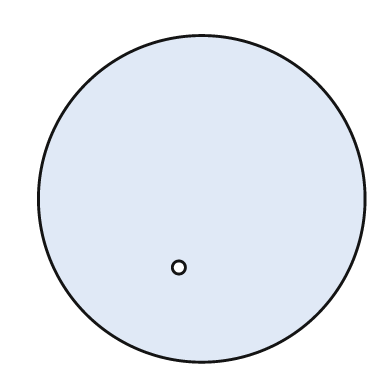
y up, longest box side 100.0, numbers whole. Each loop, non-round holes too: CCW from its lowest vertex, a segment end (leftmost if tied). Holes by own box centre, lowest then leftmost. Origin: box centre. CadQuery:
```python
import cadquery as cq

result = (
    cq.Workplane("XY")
    .moveTo(0.0, 0.0)
    .circle(50.0)
    .moveTo(-7.0, -21.0)
    .circle(2.0)
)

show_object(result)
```